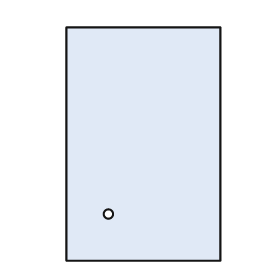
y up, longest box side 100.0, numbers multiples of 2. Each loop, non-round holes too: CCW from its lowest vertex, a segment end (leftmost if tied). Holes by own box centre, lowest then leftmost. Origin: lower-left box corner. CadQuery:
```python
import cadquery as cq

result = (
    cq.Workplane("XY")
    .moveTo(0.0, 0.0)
    .lineTo(66.0, 0.0)
    .lineTo(66.0, 100.0)
    .lineTo(0.0, 100.0)
    .close()
    .moveTo(18.0, 20.0)
    .circle(2.0)
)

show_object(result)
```